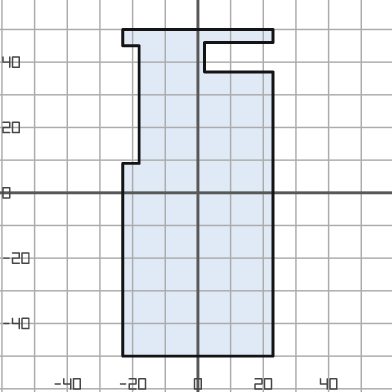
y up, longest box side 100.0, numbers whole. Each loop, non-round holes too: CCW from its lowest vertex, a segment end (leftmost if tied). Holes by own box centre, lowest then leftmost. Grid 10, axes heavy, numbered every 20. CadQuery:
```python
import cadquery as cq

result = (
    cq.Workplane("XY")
    .moveTo(-23.0, -50.0)
    .lineTo(23.0, -50.0)
    .lineTo(23.0, 37.0)
    .lineTo(2.0, 37.0)
    .lineTo(2.0, 46.0)
    .lineTo(23.0, 46.0)
    .lineTo(23.0, 50.0)
    .lineTo(-23.0, 50.0)
    .lineTo(-23.0, 45.0)
    .lineTo(-18.0, 45.0)
    .lineTo(-18.0, 9.0)
    .lineTo(-23.0, 9.0)
    .close()
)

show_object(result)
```